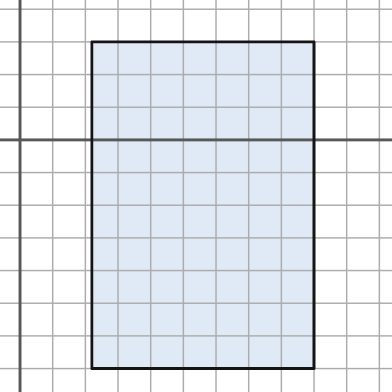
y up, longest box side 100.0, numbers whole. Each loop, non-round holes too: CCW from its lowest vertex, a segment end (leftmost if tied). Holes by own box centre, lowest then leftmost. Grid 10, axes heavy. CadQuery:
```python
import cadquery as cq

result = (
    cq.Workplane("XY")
    .moveTo(22.0, -70.0)
    .lineTo(90.0, -70.0)
    .lineTo(90.0, 30.0)
    .lineTo(22.0, 30.0)
    .close()
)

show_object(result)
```